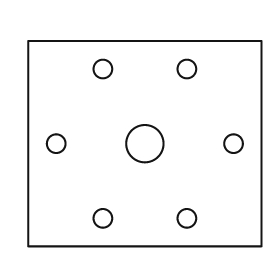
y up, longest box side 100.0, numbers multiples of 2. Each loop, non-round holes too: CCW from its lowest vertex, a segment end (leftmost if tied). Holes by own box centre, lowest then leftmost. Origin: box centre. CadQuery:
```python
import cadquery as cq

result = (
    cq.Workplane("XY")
    .moveTo(-50.0, -44.0)
    .lineTo(50.0, -44.0)
    .lineTo(50.0, 44.0)
    .lineTo(-50.0, 44.0)
    .close()
    .moveTo(-18.0, -32.0)
    .circle(4.0)
    .moveTo(18.0, -32.0)
    .circle(4.0)
    .moveTo(-38.0, 0.0)
    .circle(4.0)
    .moveTo(0.0, 0.0)
    .circle(8.0)
    .moveTo(38.0, 0.0)
    .circle(4.0)
    .moveTo(-18.0, 32.0)
    .circle(4.0)
    .moveTo(18.0, 32.0)
    .circle(4.0)
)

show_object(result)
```